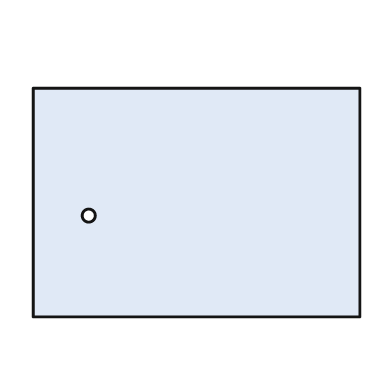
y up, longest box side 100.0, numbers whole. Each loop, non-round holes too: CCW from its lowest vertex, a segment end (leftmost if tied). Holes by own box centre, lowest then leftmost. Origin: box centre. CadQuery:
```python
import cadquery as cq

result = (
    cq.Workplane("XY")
    .moveTo(-50.0, -35.0)
    .lineTo(50.0, -35.0)
    .lineTo(50.0, 35.0)
    .lineTo(-50.0, 35.0)
    .close()
    .moveTo(-33.0, -4.0)
    .circle(2.0)
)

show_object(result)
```